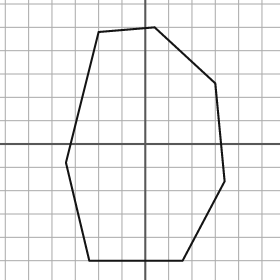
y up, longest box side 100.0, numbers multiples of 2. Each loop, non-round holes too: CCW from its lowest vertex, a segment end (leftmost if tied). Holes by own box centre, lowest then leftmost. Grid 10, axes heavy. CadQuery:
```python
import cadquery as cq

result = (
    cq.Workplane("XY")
    .moveTo(-24.0, -50.0)
    .lineTo(16.0, -50.0)
    .lineTo(34.0, -16.0)
    .lineTo(30.0, 26.0)
    .lineTo(4.0, 50.0)
    .lineTo(-20.0, 48.0)
    .lineTo(-34.0, -8.0)
    .close()
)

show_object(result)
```